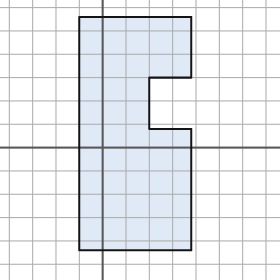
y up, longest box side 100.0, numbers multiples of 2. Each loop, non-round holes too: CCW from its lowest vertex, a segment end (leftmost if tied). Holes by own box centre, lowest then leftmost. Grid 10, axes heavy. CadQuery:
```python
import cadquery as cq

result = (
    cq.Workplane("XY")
    .moveTo(-10.0, -44.0)
    .lineTo(38.0, -44.0)
    .lineTo(38.0, 8.0)
    .lineTo(20.0, 8.0)
    .lineTo(20.0, 30.0)
    .lineTo(38.0, 30.0)
    .lineTo(38.0, 56.0)
    .lineTo(-10.0, 56.0)
    .close()
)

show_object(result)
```